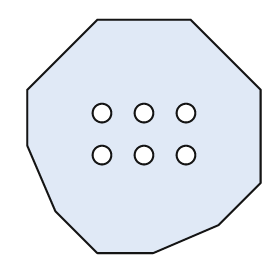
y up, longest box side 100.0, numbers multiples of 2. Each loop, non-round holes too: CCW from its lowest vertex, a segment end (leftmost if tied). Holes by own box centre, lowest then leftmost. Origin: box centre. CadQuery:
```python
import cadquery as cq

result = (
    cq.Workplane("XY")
    .moveTo(-20.0, -50.0)
    .lineTo(4.0, -50.0)
    .lineTo(32.0, -38.0)
    .lineTo(50.0, -20.0)
    .lineTo(50.0, 20.0)
    .lineTo(20.0, 50.0)
    .lineTo(-20.0, 50.0)
    .lineTo(-50.0, 20.0)
    .lineTo(-50.0, -4.0)
    .lineTo(-38.0, -32.0)
    .close()
    .moveTo(-18.0, -8.0)
    .circle(4.0)
    .moveTo(0.0, -8.0)
    .circle(4.0)
    .moveTo(18.0, -8.0)
    .circle(4.0)
    .moveTo(-18.0, 10.0)
    .circle(4.0)
    .moveTo(0.0, 10.0)
    .circle(4.0)
    .moveTo(18.0, 10.0)
    .circle(4.0)
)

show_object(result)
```